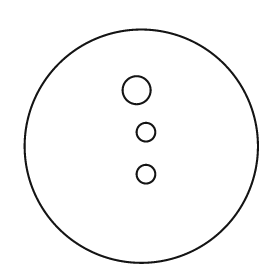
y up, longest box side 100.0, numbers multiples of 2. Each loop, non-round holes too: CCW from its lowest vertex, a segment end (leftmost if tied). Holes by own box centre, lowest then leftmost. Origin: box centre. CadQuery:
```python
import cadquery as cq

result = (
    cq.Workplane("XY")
    .moveTo(0.0, 0.0)
    .circle(50.0)
    .moveTo(2.0, -12.0)
    .circle(4.0)
    .moveTo(2.0, 6.0)
    .circle(4.0)
    .moveTo(-2.0, 24.0)
    .circle(6.0)
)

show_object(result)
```